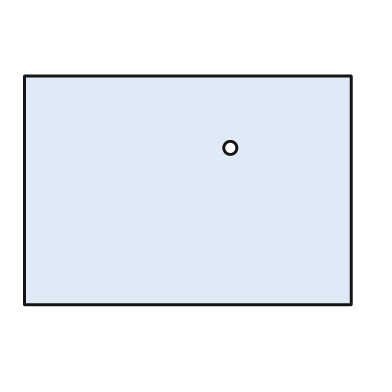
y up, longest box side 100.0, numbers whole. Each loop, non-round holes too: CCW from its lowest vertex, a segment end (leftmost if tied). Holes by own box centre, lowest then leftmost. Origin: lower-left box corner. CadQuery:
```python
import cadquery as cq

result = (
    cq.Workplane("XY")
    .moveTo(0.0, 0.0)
    .lineTo(100.0, 0.0)
    .lineTo(100.0, 70.0)
    .lineTo(0.0, 70.0)
    .close()
    .moveTo(63.0, 48.0)
    .circle(2.0)
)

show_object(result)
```